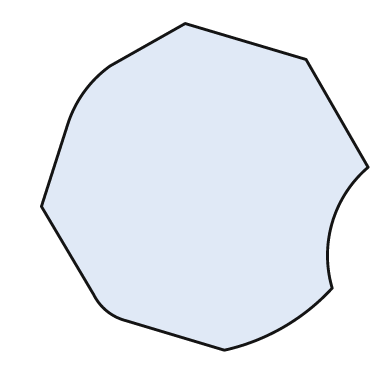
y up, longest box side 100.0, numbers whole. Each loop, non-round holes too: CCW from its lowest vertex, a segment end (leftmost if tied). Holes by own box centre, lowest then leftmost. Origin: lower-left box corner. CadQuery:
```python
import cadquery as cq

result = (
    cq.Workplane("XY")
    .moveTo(56.0, 0.0)
    .threePointArc((74.0, 7.0), (89.0, 19.0))
    .threePointArc((89.0, 39.0), (100.0, 56.0))
    .lineTo(81.0, 89.0)
    .lineTo(44.0, 100.0)
    .lineTo(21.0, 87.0)
    .threePointArc((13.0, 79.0), (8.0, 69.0))
    .lineTo(0.0, 44.0)
    .lineTo(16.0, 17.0)
    .threePointArc((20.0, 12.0), (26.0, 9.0))
    .close()
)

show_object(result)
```